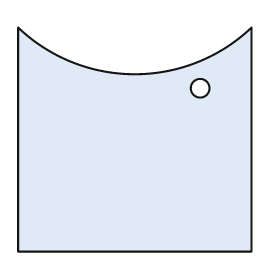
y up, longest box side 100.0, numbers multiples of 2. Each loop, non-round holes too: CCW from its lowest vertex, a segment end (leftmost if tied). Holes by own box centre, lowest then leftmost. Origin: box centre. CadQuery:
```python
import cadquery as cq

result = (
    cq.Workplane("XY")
    .moveTo(-50.0, -48.0)
    .lineTo(50.0, -48.0)
    .lineTo(50.0, 48.0)
    .threePointArc((0.0, 28.0), (-50.0, 48.0))
    .close()
    .moveTo(28.0, 22.0)
    .circle(4.0)
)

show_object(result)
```